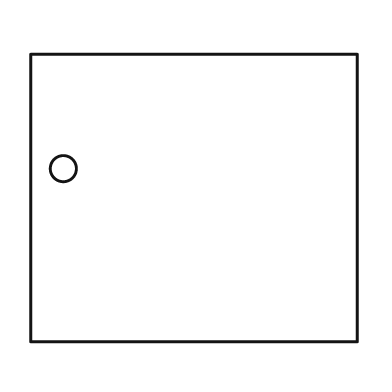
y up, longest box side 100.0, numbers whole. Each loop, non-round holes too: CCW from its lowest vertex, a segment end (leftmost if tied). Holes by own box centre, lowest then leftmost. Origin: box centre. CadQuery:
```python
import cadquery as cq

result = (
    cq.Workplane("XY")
    .moveTo(-50.0, -44.0)
    .lineTo(50.0, -44.0)
    .lineTo(50.0, 44.0)
    .lineTo(-50.0, 44.0)
    .close()
    .moveTo(-40.0, 9.0)
    .circle(4.0)
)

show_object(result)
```